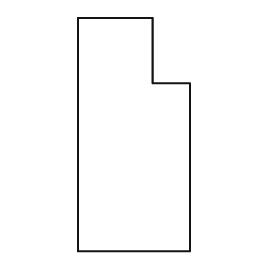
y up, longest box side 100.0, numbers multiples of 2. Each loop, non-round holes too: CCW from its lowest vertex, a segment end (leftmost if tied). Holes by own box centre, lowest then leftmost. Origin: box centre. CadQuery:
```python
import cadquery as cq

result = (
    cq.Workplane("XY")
    .moveTo(-24.0, -50.0)
    .lineTo(24.0, -50.0)
    .lineTo(24.0, 22.0)
    .lineTo(8.0, 22.0)
    .lineTo(8.0, 50.0)
    .lineTo(-24.0, 50.0)
    .close()
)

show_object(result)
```